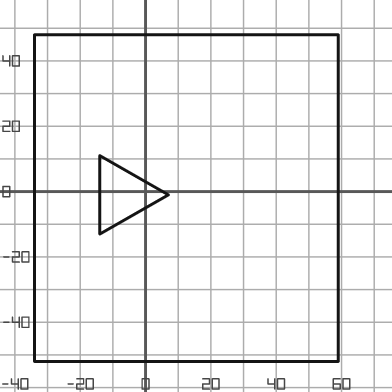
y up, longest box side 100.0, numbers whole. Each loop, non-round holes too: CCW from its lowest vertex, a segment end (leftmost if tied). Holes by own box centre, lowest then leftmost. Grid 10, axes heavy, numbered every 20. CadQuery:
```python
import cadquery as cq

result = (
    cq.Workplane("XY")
    .moveTo(-34.0, -52.0)
    .lineTo(59.0, -52.0)
    .lineTo(59.0, 48.0)
    .lineTo(-34.0, 48.0)
    .close()
    .moveTo(-14.0, -13.0)
    .lineTo(7.0, -1.0)
    .lineTo(-14.0, 11.0)
    .close()
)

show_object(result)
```